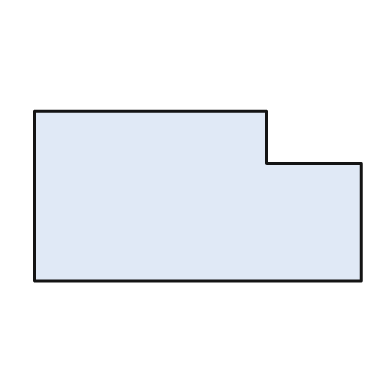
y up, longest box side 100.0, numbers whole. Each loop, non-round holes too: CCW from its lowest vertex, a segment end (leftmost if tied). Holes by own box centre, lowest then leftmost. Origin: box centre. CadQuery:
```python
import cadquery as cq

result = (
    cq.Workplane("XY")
    .moveTo(-50.0, -26.0)
    .lineTo(50.0, -26.0)
    .lineTo(50.0, 10.0)
    .lineTo(21.0, 10.0)
    .lineTo(21.0, 26.0)
    .lineTo(-50.0, 26.0)
    .close()
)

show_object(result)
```